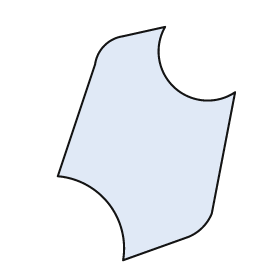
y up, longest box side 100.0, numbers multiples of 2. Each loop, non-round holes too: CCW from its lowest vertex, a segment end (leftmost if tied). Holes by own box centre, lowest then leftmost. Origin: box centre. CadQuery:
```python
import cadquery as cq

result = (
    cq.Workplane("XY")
    .moveTo(-10.0, -50.0)
    .lineTo(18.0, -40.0)
    .threePointArc((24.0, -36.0), (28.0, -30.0))
    .lineTo(38.0, 22.0)
    .threePointArc((12.0, 24.0), (8.0, 50.0))
    .lineTo(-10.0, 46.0)
    .threePointArc((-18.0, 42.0), (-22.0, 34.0))
    .lineTo(-38.0, -14.0)
    .threePointArc((-16.0, -26.0), (-10.0, -50.0))
    .close()
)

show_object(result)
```